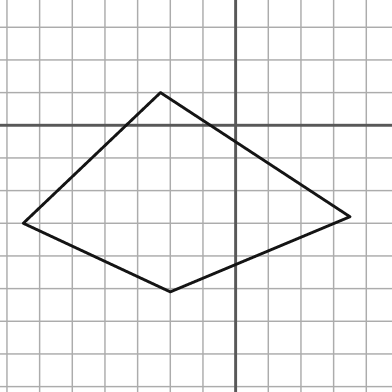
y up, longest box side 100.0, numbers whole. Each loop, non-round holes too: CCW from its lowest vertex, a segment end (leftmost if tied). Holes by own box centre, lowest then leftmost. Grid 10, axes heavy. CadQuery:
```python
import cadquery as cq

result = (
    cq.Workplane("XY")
    .moveTo(-20.0, -51.0)
    .lineTo(35.0, -28.0)
    .lineTo(-23.0, 10.0)
    .lineTo(-65.0, -30.0)
    .close()
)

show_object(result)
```